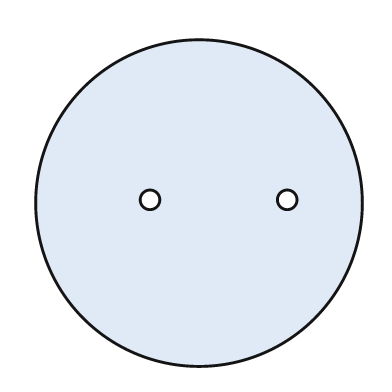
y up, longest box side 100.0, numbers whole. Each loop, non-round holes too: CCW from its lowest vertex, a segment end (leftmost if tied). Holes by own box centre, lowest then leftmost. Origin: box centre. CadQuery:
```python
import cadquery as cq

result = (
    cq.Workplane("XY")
    .moveTo(0.0, 0.0)
    .circle(50.0)
    .moveTo(-15.0, 1.0)
    .circle(3.0)
    .moveTo(27.0, 1.0)
    .circle(3.0)
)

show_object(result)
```